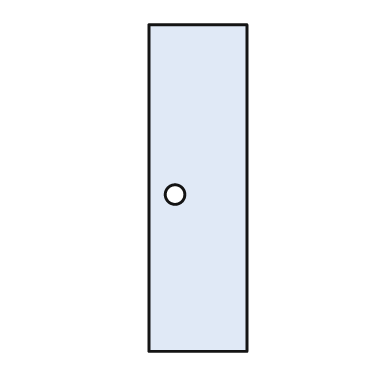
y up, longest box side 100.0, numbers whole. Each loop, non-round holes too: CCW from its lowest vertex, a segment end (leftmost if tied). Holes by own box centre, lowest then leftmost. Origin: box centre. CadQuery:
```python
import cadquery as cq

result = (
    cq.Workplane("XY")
    .moveTo(-15.0, -50.0)
    .lineTo(15.0, -50.0)
    .lineTo(15.0, 50.0)
    .lineTo(-15.0, 50.0)
    .close()
    .moveTo(-7.0, -2.0)
    .circle(3.0)
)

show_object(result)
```